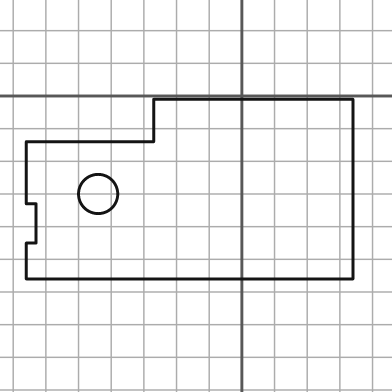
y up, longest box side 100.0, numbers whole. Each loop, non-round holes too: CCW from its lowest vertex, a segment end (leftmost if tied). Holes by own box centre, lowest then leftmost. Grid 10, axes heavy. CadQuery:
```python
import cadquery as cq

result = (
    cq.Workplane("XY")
    .moveTo(-66.0, -56.0)
    .lineTo(34.0, -56.0)
    .lineTo(34.0, -1.0)
    .lineTo(-27.0, -1.0)
    .lineTo(-27.0, -14.0)
    .lineTo(-66.0, -14.0)
    .lineTo(-66.0, -33.0)
    .lineTo(-63.0, -33.0)
    .lineTo(-63.0, -45.0)
    .lineTo(-66.0, -45.0)
    .close()
    .moveTo(-44.0, -30.0)
    .circle(6.0)
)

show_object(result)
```